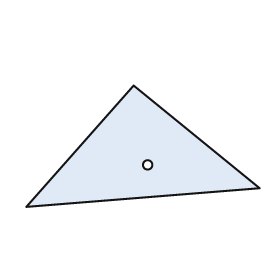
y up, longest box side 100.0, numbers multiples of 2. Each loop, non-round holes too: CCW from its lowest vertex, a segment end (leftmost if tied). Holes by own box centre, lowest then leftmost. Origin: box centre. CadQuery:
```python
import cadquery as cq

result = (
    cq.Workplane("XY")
    .moveTo(-50.0, -26.0)
    .lineTo(50.0, -18.0)
    .lineTo(-4.0, 26.0)
    .close()
    .moveTo(2.0, -8.0)
    .circle(2.0)
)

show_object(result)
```